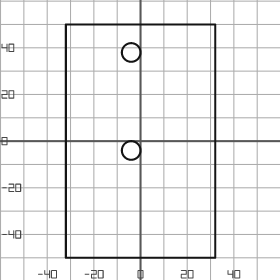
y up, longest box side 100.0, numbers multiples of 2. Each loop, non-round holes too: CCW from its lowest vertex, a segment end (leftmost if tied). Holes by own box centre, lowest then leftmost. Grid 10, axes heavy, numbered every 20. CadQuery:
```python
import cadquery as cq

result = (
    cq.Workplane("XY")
    .moveTo(-32.0, -50.0)
    .lineTo(32.0, -50.0)
    .lineTo(32.0, 50.0)
    .lineTo(-32.0, 50.0)
    .close()
    .moveTo(-4.0, -4.0)
    .circle(4.0)
    .moveTo(-4.0, 38.0)
    .circle(4.0)
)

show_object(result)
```